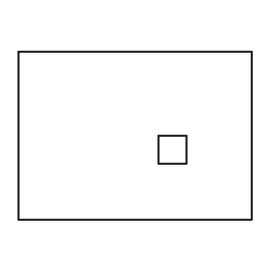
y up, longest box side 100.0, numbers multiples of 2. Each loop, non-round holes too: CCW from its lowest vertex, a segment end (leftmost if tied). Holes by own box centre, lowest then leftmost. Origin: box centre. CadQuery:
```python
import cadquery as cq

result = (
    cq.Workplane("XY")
    .moveTo(-50.0, -36.0)
    .lineTo(50.0, -36.0)
    .lineTo(50.0, 36.0)
    .lineTo(-50.0, 36.0)
    .close()
    .moveTo(10.0, -12.0)
    .lineTo(22.0, -12.0)
    .lineTo(22.0, 0.0)
    .lineTo(10.0, 0.0)
    .close()
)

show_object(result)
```